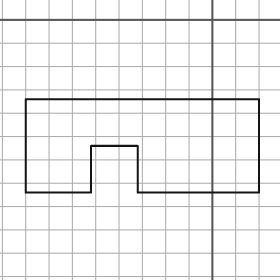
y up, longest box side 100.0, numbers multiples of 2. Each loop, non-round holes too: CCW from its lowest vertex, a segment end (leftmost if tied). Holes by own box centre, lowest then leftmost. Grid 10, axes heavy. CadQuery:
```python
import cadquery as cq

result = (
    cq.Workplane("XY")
    .moveTo(-80.0, -74.0)
    .lineTo(-52.0, -74.0)
    .lineTo(-52.0, -54.0)
    .lineTo(-32.0, -54.0)
    .lineTo(-32.0, -74.0)
    .lineTo(20.0, -74.0)
    .lineTo(20.0, -34.0)
    .lineTo(-80.0, -34.0)
    .close()
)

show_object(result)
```